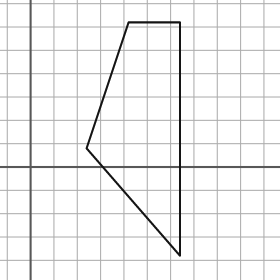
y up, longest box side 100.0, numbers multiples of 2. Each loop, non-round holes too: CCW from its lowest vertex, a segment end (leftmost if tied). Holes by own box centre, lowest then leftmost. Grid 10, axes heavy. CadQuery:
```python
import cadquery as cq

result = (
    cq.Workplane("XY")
    .moveTo(64.0, -38.0)
    .lineTo(64.0, 62.0)
    .lineTo(42.0, 62.0)
    .lineTo(24.0, 8.0)
    .close()
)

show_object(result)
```